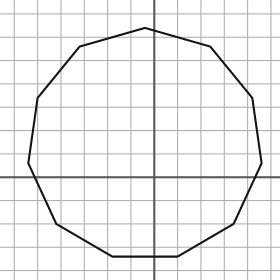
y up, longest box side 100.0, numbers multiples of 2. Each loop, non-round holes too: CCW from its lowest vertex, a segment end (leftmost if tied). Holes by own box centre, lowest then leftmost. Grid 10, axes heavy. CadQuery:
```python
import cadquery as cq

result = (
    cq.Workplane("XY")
    .moveTo(-18.0, -34.0)
    .lineTo(10.0, -34.0)
    .lineTo(34.0, -20.0)
    .lineTo(46.0, 6.0)
    .lineTo(42.0, 34.0)
    .lineTo(24.0, 56.0)
    .lineTo(-4.0, 64.0)
    .lineTo(-32.0, 56.0)
    .lineTo(-50.0, 34.0)
    .lineTo(-54.0, 6.0)
    .lineTo(-42.0, -20.0)
    .close()
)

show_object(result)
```